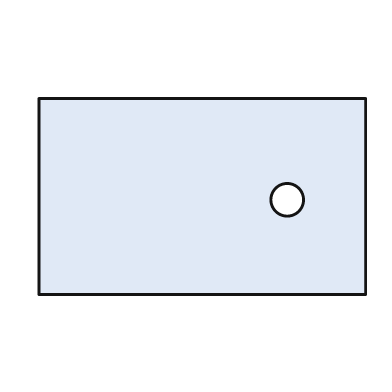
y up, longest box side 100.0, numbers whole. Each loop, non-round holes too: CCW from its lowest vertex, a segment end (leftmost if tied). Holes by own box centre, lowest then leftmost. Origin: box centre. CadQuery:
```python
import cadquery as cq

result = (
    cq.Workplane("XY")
    .moveTo(-50.0, -30.0)
    .lineTo(50.0, -30.0)
    .lineTo(50.0, 30.0)
    .lineTo(-50.0, 30.0)
    .close()
    .moveTo(26.0, -1.0)
    .circle(5.0)
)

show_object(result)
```